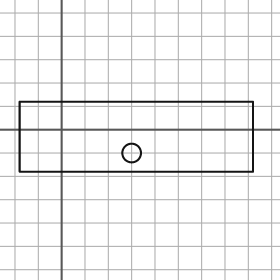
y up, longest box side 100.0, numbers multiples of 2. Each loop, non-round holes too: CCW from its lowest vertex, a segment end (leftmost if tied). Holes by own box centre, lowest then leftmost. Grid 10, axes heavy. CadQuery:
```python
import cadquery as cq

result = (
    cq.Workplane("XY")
    .moveTo(-18.0, -18.0)
    .lineTo(82.0, -18.0)
    .lineTo(82.0, 12.0)
    .lineTo(-18.0, 12.0)
    .close()
    .moveTo(30.0, -10.0)
    .circle(4.0)
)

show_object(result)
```